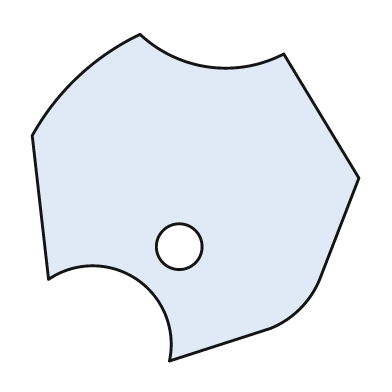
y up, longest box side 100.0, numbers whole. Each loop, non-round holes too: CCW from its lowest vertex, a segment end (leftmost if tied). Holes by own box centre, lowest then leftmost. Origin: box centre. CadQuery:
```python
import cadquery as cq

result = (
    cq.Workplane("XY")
    .moveTo(-8.0, -50.0)
    .lineTo(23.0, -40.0)
    .threePointArc((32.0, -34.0), (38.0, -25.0))
    .lineTo(50.0, 6.0)
    .lineTo(27.0, 44.0)
    .threePointArc((4.0, 40.0), (-17.0, 50.0))
    .threePointArc((-36.0, 37.0), (-50.0, 19.0))
    .lineTo(-45.0, -25.0)
    .threePointArc((-18.0, -25.0), (-8.0, -50.0))
    .close()
    .moveTo(-5.0, -15.0)
    .circle(7.0)
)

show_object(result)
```